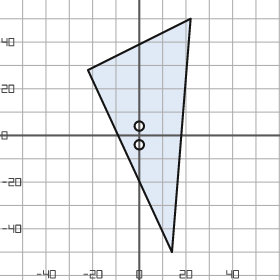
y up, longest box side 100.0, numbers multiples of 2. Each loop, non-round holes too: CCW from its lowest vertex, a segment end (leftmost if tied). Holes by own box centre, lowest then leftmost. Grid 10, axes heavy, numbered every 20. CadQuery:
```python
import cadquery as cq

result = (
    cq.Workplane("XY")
    .moveTo(14.0, -50.0)
    .lineTo(22.0, 50.0)
    .lineTo(-22.0, 28.0)
    .close()
    .moveTo(0.0, -4.0)
    .circle(2.0)
    .moveTo(0.0, 4.0)
    .circle(2.0)
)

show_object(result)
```